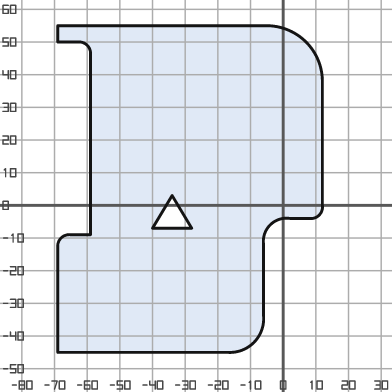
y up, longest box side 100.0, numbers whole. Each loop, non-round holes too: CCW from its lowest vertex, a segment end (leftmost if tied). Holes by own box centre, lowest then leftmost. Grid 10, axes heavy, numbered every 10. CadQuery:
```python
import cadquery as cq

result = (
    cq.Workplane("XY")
    .moveTo(-69.0, -45.0)
    .lineTo(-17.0, -45.0)
    .threePointArc((-9.0, -42.0), (-6.0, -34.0))
    .lineTo(-6.0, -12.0)
    .threePointArc((-4.0, -6.0), (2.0, -4.0))
    .lineTo(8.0, -4.0)
    .threePointArc((11.0, -3.0), (12.0, 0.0))
    .lineTo(12.0, 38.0)
    .threePointArc((7.0, 50.0), (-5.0, 55.0))
    .lineTo(-69.0, 55.0)
    .lineTo(-69.0, 50.0)
    .lineTo(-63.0, 50.0)
    .threePointArc((-60.0, 49.0), (-59.0, 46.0))
    .lineTo(-59.0, -9.0)
    .lineTo(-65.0, -9.0)
    .threePointArc((-68.0, -10.0), (-69.0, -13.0))
    .close()
    .moveTo(-40.0, -7.0)
    .lineTo(-28.0, -7.0)
    .lineTo(-34.0, 3.0)
    .close()
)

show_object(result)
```